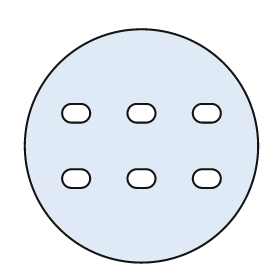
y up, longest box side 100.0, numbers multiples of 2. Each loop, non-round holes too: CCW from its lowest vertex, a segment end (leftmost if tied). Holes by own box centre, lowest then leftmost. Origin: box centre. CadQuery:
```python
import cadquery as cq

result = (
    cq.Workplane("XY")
    .moveTo(0.0, 0.0)
    .circle(50.0)
    .moveTo(-30.0, -18.0)
    .lineTo(-26.0, -18.0)
    .threePointArc((-22.0, -14.0), (-26.0, -10.0))
    .lineTo(-30.0, -10.0)
    .threePointArc((-34.0, -14.0), (-30.0, -18.0))
    .close()
    .moveTo(-2.0, -18.0)
    .lineTo(2.0, -18.0)
    .threePointArc((6.0, -14.0), (2.0, -10.0))
    .lineTo(-2.0, -10.0)
    .threePointArc((-6.0, -14.0), (-2.0, -18.0))
    .close()
    .moveTo(26.0, -18.0)
    .lineTo(30.0, -18.0)
    .threePointArc((34.0, -14.0), (30.0, -10.0))
    .lineTo(26.0, -10.0)
    .threePointArc((22.0, -14.0), (26.0, -18.0))
    .close()
    .moveTo(-30.0, 10.0)
    .lineTo(-26.0, 10.0)
    .threePointArc((-22.0, 14.0), (-26.0, 18.0))
    .lineTo(-30.0, 18.0)
    .threePointArc((-34.0, 14.0), (-30.0, 10.0))
    .close()
    .moveTo(-2.0, 10.0)
    .lineTo(2.0, 10.0)
    .threePointArc((6.0, 14.0), (2.0, 18.0))
    .lineTo(-2.0, 18.0)
    .threePointArc((-6.0, 14.0), (-2.0, 10.0))
    .close()
    .moveTo(26.0, 10.0)
    .lineTo(30.0, 10.0)
    .threePointArc((34.0, 14.0), (30.0, 18.0))
    .lineTo(26.0, 18.0)
    .threePointArc((22.0, 14.0), (26.0, 10.0))
    .close()
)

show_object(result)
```